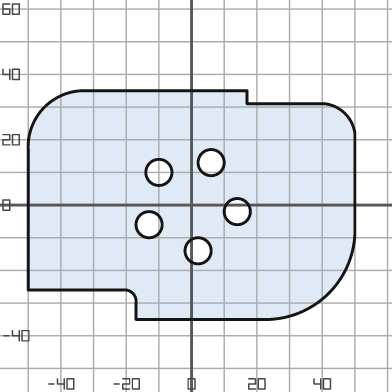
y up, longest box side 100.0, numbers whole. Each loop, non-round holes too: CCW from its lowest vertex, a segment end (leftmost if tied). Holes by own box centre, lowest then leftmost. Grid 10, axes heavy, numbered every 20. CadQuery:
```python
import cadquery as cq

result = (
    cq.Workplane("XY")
    .moveTo(-17.0, -35.0)
    .lineTo(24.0, -35.0)
    .threePointArc((42.0, -27.0), (50.0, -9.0))
    .lineTo(50.0, 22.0)
    .threePointArc((47.0, 28.0), (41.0, 31.0))
    .lineTo(17.0, 31.0)
    .lineTo(17.0, 35.0)
    .lineTo(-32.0, 35.0)
    .threePointArc((-45.0, 30.0), (-50.0, 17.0))
    .lineTo(-50.0, -26.0)
    .lineTo(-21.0, -26.0)
    .threePointArc((-18.0, -27.0), (-17.0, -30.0))
    .close()
    .moveTo(2.0, -14.0)
    .circle(4.0)
    .moveTo(-13.0, -6.0)
    .circle(4.0)
    .moveTo(14.0, -2.0)
    .circle(4.0)
    .moveTo(-10.0, 10.0)
    .circle(4.0)
    .moveTo(6.0, 13.0)
    .circle(4.0)
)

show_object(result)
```